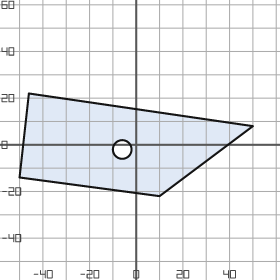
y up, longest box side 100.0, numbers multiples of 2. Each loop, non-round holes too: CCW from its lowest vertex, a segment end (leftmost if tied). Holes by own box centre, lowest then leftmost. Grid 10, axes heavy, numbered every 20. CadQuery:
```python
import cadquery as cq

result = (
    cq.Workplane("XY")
    .moveTo(10.0, -22.0)
    .lineTo(50.0, 8.0)
    .lineTo(-46.0, 22.0)
    .lineTo(-50.0, -14.0)
    .close()
    .moveTo(-6.0, -2.0)
    .circle(4.0)
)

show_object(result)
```